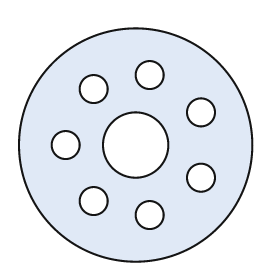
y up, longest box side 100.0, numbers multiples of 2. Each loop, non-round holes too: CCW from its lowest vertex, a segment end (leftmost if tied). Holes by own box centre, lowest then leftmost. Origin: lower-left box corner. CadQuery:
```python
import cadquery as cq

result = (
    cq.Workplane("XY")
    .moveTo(50.0, 50.0)
    .circle(50.0)
    .moveTo(56.0, 20.0)
    .circle(6.0)
    .moveTo(32.0, 26.0)
    .circle(6.0)
    .moveTo(78.0, 36.0)
    .circle(6.0)
    .moveTo(20.0, 50.0)
    .circle(6.0)
    .moveTo(50.0, 50.0)
    .circle(14.0)
    .moveTo(78.0, 64.0)
    .circle(6.0)
    .moveTo(32.0, 74.0)
    .circle(6.0)
    .moveTo(56.0, 80.0)
    .circle(6.0)
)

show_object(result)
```